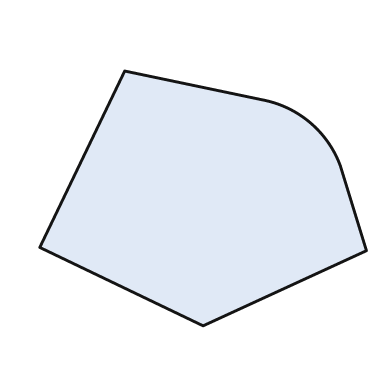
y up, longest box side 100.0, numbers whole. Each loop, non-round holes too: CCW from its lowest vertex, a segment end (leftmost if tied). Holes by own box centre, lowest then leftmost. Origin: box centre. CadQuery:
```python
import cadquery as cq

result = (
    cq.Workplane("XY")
    .moveTo(0.0, -39.0)
    .lineTo(50.0, -16.0)
    .lineTo(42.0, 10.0)
    .threePointArc((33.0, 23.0), (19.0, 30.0))
    .lineTo(-24.0, 39.0)
    .lineTo(-50.0, -15.0)
    .close()
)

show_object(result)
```